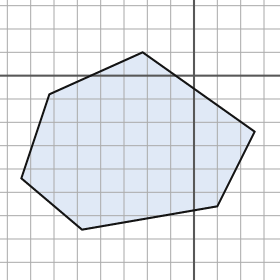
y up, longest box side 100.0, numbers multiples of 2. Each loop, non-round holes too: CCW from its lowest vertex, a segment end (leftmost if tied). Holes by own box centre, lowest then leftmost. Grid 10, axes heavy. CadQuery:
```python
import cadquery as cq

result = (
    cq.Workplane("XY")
    .moveTo(-48.0, -66.0)
    .lineTo(10.0, -56.0)
    .lineTo(26.0, -24.0)
    .lineTo(-22.0, 10.0)
    .lineTo(-62.0, -8.0)
    .lineTo(-74.0, -44.0)
    .close()
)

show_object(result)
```